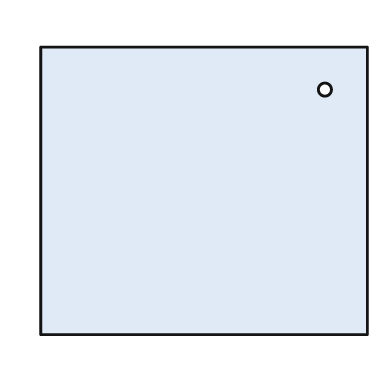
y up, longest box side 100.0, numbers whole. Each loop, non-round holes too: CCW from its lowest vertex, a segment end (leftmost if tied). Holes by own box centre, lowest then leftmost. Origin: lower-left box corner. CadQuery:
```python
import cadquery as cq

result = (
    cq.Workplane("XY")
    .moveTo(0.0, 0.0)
    .lineTo(100.0, 0.0)
    .lineTo(100.0, 88.0)
    .lineTo(0.0, 88.0)
    .close()
    .moveTo(87.0, 75.0)
    .circle(2.0)
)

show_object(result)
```